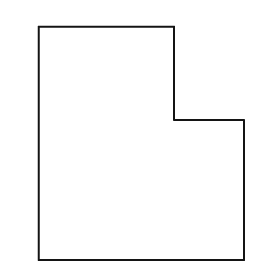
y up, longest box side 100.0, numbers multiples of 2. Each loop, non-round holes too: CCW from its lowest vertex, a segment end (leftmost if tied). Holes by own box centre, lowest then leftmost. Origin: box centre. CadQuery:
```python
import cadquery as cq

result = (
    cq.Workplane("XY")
    .moveTo(-44.0, -50.0)
    .lineTo(44.0, -50.0)
    .lineTo(44.0, 10.0)
    .lineTo(14.0, 10.0)
    .lineTo(14.0, 50.0)
    .lineTo(-44.0, 50.0)
    .close()
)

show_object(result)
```